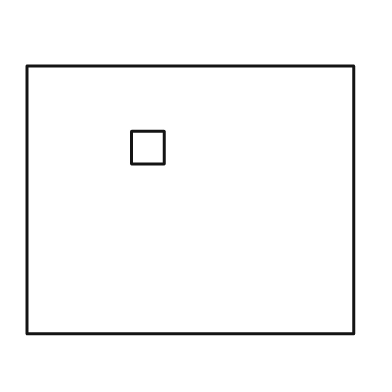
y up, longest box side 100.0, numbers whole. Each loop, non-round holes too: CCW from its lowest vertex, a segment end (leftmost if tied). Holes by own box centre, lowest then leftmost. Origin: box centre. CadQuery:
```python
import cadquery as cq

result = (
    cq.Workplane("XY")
    .moveTo(-50.0, -41.0)
    .lineTo(50.0, -41.0)
    .lineTo(50.0, 41.0)
    .lineTo(-50.0, 41.0)
    .close()
    .moveTo(-18.0, 11.0)
    .lineTo(-8.0, 11.0)
    .lineTo(-8.0, 21.0)
    .lineTo(-18.0, 21.0)
    .close()
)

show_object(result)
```